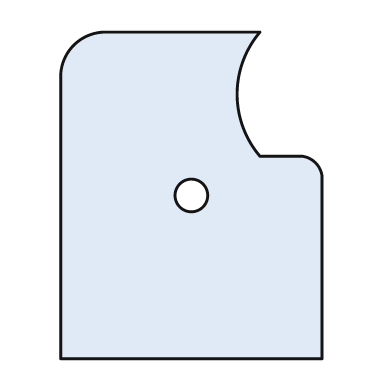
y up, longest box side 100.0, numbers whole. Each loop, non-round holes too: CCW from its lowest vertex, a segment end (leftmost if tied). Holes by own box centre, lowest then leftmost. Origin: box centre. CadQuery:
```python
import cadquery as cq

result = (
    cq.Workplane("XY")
    .moveTo(-40.0, -50.0)
    .lineTo(40.0, -50.0)
    .lineTo(40.0, 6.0)
    .threePointArc((38.0, 10.0), (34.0, 12.0))
    .lineTo(21.0, 12.0)
    .threePointArc((14.0, 31.0), (21.0, 50.0))
    .lineTo(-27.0, 50.0)
    .threePointArc((-36.0, 46.0), (-40.0, 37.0))
    .close()
    .moveTo(0.0, 0.0)
    .circle(5.0)
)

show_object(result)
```